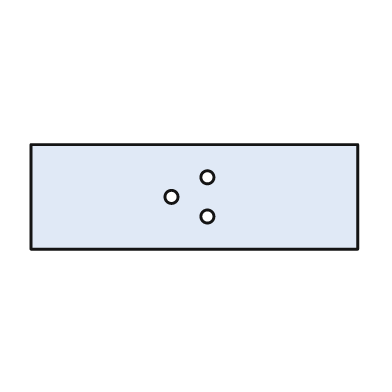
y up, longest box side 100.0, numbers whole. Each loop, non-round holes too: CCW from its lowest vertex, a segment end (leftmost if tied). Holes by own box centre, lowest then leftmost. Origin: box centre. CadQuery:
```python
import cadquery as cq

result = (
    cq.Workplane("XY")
    .moveTo(-50.0, -16.0)
    .lineTo(50.0, -16.0)
    .lineTo(50.0, 16.0)
    .lineTo(-50.0, 16.0)
    .close()
    .moveTo(4.0, -6.0)
    .circle(2.0)
    .moveTo(-7.0, 0.0)
    .circle(2.0)
    .moveTo(4.0, 6.0)
    .circle(2.0)
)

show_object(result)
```